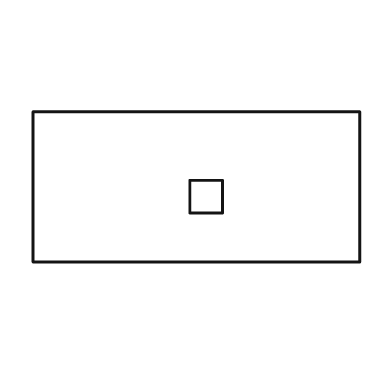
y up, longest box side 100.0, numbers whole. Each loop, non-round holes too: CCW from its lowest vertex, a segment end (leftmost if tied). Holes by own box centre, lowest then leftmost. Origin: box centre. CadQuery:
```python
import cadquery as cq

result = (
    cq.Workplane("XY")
    .moveTo(-50.0, -23.0)
    .lineTo(50.0, -23.0)
    .lineTo(50.0, 23.0)
    .lineTo(-50.0, 23.0)
    .close()
    .moveTo(-2.0, -8.0)
    .lineTo(8.0, -8.0)
    .lineTo(8.0, 2.0)
    .lineTo(-2.0, 2.0)
    .close()
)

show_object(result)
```